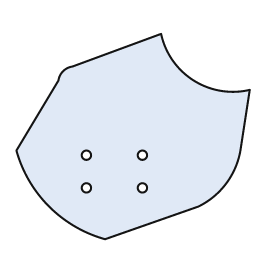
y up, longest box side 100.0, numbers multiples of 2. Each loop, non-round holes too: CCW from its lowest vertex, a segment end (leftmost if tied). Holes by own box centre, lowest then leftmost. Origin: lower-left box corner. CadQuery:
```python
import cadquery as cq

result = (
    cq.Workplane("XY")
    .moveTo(38.0, 0.0)
    .lineTo(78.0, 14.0)
    .threePointArc((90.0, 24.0), (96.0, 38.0))
    .lineTo(100.0, 64.0)
    .threePointArc((76.0, 68.0), (62.0, 88.0))
    .lineTo(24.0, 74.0)
    .threePointArc((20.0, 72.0), (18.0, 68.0))
    .lineTo(0.0, 38.0)
    .threePointArc((14.0, 14.0), (38.0, 0.0))
    .close()
    .moveTo(30.0, 22.0)
    .circle(2.0)
    .moveTo(54.0, 22.0)
    .circle(2.0)
    .moveTo(30.0, 36.0)
    .circle(2.0)
    .moveTo(54.0, 36.0)
    .circle(2.0)
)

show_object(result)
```